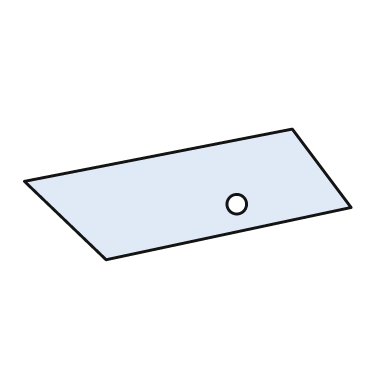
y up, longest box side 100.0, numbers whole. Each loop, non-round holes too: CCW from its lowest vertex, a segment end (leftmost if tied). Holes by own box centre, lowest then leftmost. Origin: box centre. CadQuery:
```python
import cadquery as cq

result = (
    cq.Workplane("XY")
    .moveTo(-25.0, -20.0)
    .lineTo(50.0, -4.0)
    .lineTo(32.0, 20.0)
    .lineTo(-50.0, 4.0)
    .close()
    .moveTo(15.0, -3.0)
    .circle(3.0)
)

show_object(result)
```